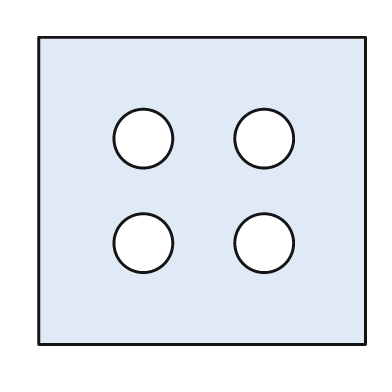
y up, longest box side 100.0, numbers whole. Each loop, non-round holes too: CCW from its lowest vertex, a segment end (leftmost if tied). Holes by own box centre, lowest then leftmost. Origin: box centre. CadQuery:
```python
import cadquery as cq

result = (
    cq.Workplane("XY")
    .moveTo(-50.0, -47.0)
    .lineTo(50.0, -47.0)
    .lineTo(50.0, 47.0)
    .lineTo(-50.0, 47.0)
    .close()
    .moveTo(-18.0, -16.0)
    .circle(9.0)
    .moveTo(19.0, -16.0)
    .circle(9.0)
    .moveTo(-18.0, 16.0)
    .circle(9.0)
    .moveTo(19.0, 16.0)
    .circle(9.0)
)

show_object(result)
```